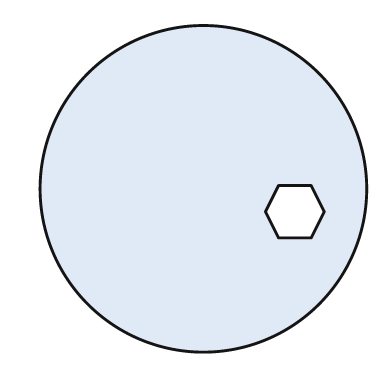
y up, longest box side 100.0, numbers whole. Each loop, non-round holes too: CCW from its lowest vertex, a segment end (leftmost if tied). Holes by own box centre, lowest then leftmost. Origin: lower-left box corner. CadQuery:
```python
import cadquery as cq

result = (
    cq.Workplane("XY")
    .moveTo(50.0, 50.0)
    .circle(50.0)
    .moveTo(73.0, 35.0)
    .lineTo(83.0, 35.0)
    .lineTo(87.0, 43.0)
    .lineTo(83.0, 51.0)
    .lineTo(73.0, 51.0)
    .lineTo(69.0, 43.0)
    .close()
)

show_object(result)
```